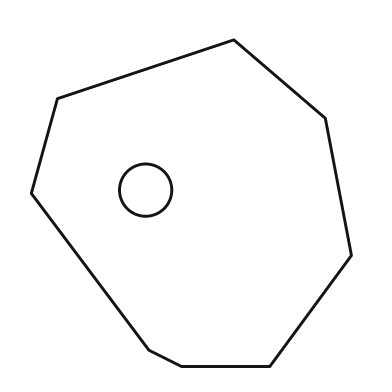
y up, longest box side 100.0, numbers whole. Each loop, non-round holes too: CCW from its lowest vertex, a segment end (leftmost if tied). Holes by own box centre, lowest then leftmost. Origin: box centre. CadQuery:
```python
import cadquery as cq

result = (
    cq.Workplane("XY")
    .moveTo(-3.0, -50.0)
    .lineTo(24.0, -50.0)
    .lineTo(49.0, -16.0)
    .lineTo(41.0, 26.0)
    .lineTo(13.0, 50.0)
    .lineTo(-41.0, 32.0)
    .lineTo(-49.0, 3.0)
    .lineTo(-13.0, -45.0)
    .close()
    .moveTo(-14.0, 4.0)
    .circle(8.0)
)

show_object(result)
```